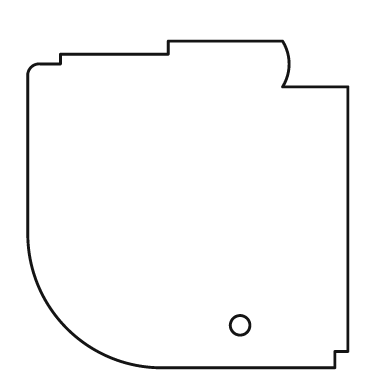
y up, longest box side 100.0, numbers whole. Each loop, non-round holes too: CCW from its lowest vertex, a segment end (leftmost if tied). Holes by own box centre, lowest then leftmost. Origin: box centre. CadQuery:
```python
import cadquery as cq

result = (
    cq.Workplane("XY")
    .moveTo(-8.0, -50.0)
    .lineTo(45.0, -50.0)
    .lineTo(45.0, -45.0)
    .lineTo(49.0, -45.0)
    .lineTo(49.0, 36.0)
    .lineTo(29.0, 36.0)
    .threePointArc((31.0, 43.0), (29.0, 50.0))
    .lineTo(-6.0, 50.0)
    .lineTo(-6.0, 46.0)
    .lineTo(-39.0, 46.0)
    .lineTo(-39.0, 43.0)
    .lineTo(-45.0, 43.0)
    .threePointArc((-48.0, 42.0), (-49.0, 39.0))
    .lineTo(-49.0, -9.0)
    .threePointArc((-37.0, -38.0), (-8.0, -50.0))
    .close()
    .moveTo(16.0, -37.0)
    .circle(3.0)
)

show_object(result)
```